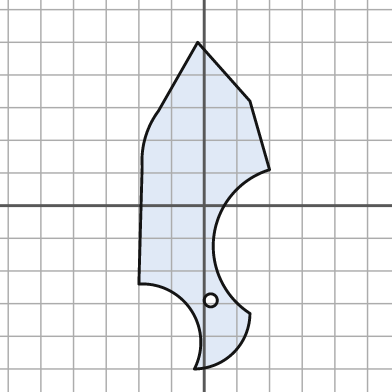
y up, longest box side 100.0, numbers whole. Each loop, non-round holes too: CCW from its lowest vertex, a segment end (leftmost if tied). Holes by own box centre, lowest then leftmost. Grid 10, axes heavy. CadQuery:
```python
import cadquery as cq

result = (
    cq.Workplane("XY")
    .moveTo(-3.0, -50.0)
    .threePointArc((9.0, -45.0), (14.0, -33.0))
    .threePointArc((3.0, -9.0), (20.0, 11.0))
    .lineTo(14.0, 32.0)
    .lineTo(-2.0, 50.0)
    .lineTo(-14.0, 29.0)
    .threePointArc((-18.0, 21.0), (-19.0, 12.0))
    .lineTo(-20.0, -24.0)
    .threePointArc((-4.0, -32.0), (-3.0, -50.0))
    .close()
    .moveTo(2.0, -29.0)
    .circle(2.0)
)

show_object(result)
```